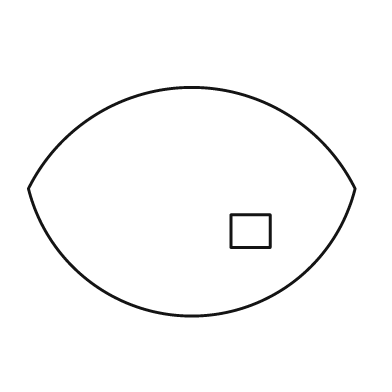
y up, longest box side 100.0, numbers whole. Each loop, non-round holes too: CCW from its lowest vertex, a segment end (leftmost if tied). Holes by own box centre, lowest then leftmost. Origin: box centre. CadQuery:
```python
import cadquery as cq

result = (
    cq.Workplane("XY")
    .moveTo(-50.0, 4.0)
    .threePointArc((0.0, -35.0), (50.0, 4.0))
    .threePointArc((0.0, 35.0), (-50.0, 4.0))
    .close()
    .moveTo(12.0, -14.0)
    .lineTo(24.0, -14.0)
    .lineTo(24.0, -4.0)
    .lineTo(12.0, -4.0)
    .close()
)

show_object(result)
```